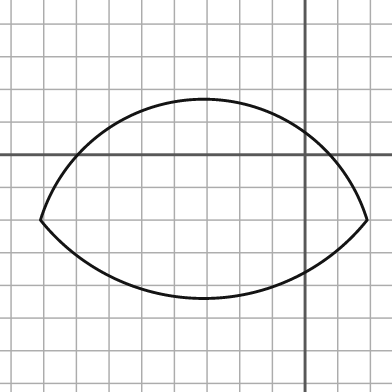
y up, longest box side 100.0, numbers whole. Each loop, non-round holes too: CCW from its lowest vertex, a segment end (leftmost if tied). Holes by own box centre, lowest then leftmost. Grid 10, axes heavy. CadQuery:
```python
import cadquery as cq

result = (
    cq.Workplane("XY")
    .moveTo(-81.0, -20.0)
    .threePointArc((-31.0, -44.0), (19.0, -20.0))
    .threePointArc((-31.0, 17.0), (-81.0, -20.0))
    .close()
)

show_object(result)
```